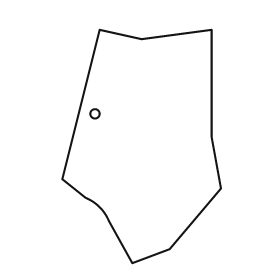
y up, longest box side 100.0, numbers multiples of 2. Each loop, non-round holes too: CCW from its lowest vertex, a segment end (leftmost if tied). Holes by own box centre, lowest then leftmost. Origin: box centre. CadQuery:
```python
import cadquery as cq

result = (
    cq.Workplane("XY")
    .moveTo(-4.0, -50.0)
    .lineTo(12.0, -44.0)
    .lineTo(34.0, -18.0)
    .lineTo(30.0, 4.0)
    .lineTo(30.0, 50.0)
    .lineTo(0.0, 46.0)
    .lineTo(-18.0, 50.0)
    .lineTo(-34.0, -14.0)
    .lineTo(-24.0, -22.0)
    .threePointArc((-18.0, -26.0), (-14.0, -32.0))
    .close()
    .moveTo(-20.0, 14.0)
    .circle(2.0)
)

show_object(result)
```